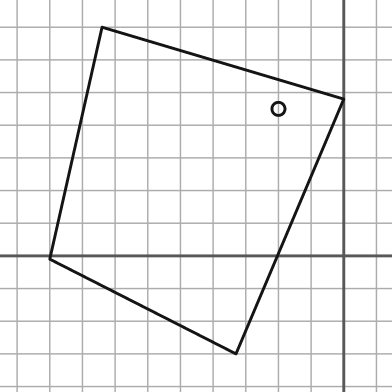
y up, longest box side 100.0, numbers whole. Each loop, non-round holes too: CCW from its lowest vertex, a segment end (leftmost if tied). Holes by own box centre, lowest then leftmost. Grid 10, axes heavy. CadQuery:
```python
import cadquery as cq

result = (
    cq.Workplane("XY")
    .moveTo(-33.0, -30.0)
    .lineTo(0.0, 48.0)
    .lineTo(-74.0, 70.0)
    .lineTo(-90.0, -1.0)
    .close()
    .moveTo(-20.0, 45.0)
    .circle(2.0)
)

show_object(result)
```